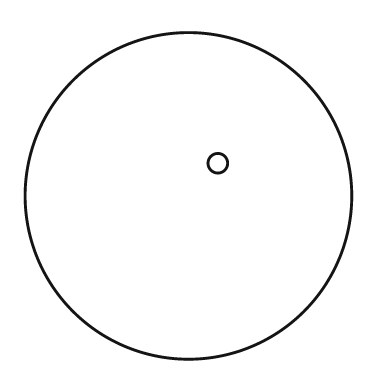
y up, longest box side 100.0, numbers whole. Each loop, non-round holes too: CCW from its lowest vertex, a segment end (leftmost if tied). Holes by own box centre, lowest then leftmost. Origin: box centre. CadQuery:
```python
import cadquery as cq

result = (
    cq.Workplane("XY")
    .moveTo(0.0, 0.0)
    .circle(50.0)
    .moveTo(9.0, 10.0)
    .circle(3.0)
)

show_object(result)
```